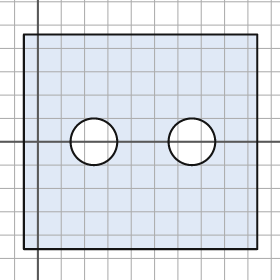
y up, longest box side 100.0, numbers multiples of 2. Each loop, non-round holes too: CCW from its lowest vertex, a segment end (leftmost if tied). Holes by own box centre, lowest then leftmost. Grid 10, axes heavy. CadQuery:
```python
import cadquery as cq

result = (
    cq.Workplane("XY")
    .moveTo(-6.0, -46.0)
    .lineTo(94.0, -46.0)
    .lineTo(94.0, 46.0)
    .lineTo(-6.0, 46.0)
    .close()
    .moveTo(24.0, 0.0)
    .circle(10.0)
    .moveTo(66.0, 0.0)
    .circle(10.0)
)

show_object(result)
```